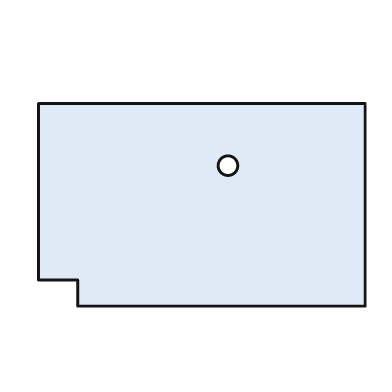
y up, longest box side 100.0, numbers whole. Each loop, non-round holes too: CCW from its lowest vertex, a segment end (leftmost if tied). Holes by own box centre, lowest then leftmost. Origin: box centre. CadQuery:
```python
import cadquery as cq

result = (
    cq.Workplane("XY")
    .moveTo(-38.0, -31.0)
    .lineTo(50.0, -31.0)
    .lineTo(50.0, 31.0)
    .lineTo(-50.0, 31.0)
    .lineTo(-50.0, -23.0)
    .lineTo(-38.0, -23.0)
    .close()
    .moveTo(8.0, 12.0)
    .circle(3.0)
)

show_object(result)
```